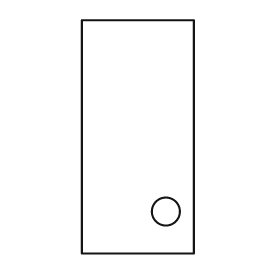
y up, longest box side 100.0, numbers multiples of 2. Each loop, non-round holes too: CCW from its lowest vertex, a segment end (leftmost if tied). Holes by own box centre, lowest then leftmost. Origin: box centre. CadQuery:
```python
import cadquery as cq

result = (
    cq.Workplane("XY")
    .moveTo(-24.0, -50.0)
    .lineTo(24.0, -50.0)
    .lineTo(24.0, 50.0)
    .lineTo(-24.0, 50.0)
    .close()
    .moveTo(12.0, -32.0)
    .circle(6.0)
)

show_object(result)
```